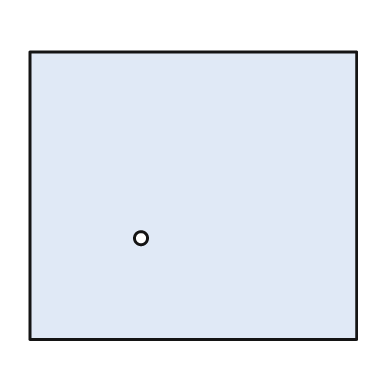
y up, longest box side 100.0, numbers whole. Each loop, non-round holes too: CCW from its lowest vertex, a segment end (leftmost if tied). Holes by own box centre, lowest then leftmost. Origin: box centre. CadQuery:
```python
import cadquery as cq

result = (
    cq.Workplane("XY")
    .moveTo(-50.0, -44.0)
    .lineTo(50.0, -44.0)
    .lineTo(50.0, 44.0)
    .lineTo(-50.0, 44.0)
    .close()
    .moveTo(-16.0, -13.0)
    .circle(2.0)
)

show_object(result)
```